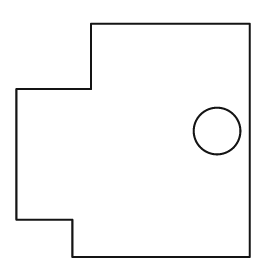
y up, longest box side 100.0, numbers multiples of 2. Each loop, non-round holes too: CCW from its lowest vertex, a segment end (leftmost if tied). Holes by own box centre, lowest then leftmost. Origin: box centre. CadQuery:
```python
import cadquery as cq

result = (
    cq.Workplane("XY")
    .moveTo(-26.0, -50.0)
    .lineTo(50.0, -50.0)
    .lineTo(50.0, 50.0)
    .lineTo(-18.0, 50.0)
    .lineTo(-18.0, 22.0)
    .lineTo(-50.0, 22.0)
    .lineTo(-50.0, -34.0)
    .lineTo(-26.0, -34.0)
    .close()
    .moveTo(36.0, 4.0)
    .circle(10.0)
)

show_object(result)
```